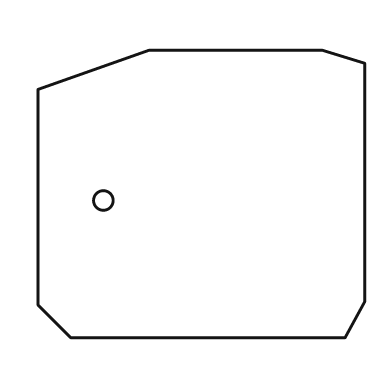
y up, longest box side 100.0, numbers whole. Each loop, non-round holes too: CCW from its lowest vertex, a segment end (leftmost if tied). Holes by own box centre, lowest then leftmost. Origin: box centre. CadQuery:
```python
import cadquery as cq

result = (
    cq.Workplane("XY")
    .moveTo(-40.0, -44.0)
    .lineTo(44.0, -44.0)
    .lineTo(50.0, -33.0)
    .lineTo(50.0, 40.0)
    .lineTo(37.0, 44.0)
    .lineTo(-16.0, 44.0)
    .lineTo(-50.0, 32.0)
    .lineTo(-50.0, -34.0)
    .close()
    .moveTo(-30.0, -2.0)
    .circle(3.0)
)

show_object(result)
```